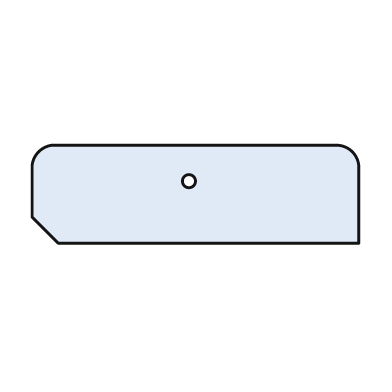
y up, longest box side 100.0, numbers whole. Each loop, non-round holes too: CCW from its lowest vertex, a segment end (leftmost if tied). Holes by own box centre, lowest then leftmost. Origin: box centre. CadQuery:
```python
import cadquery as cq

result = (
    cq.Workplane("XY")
    .moveTo(-42.0, -15.0)
    .lineTo(50.0, -15.0)
    .lineTo(50.0, 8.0)
    .threePointArc((48.0, 13.0), (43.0, 15.0))
    .lineTo(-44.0, 15.0)
    .threePointArc((-48.0, 13.0), (-50.0, 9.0))
    .lineTo(-50.0, -7.0)
    .close()
    .moveTo(-2.0, 4.0)
    .circle(2.0)
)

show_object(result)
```